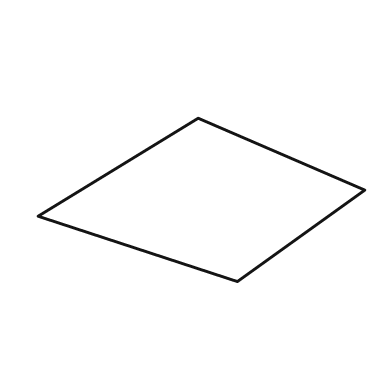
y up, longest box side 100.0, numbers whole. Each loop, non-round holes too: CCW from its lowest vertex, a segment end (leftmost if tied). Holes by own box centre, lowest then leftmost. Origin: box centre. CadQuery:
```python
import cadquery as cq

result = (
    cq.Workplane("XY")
    .moveTo(11.0, -25.0)
    .lineTo(50.0, 3.0)
    .lineTo(-1.0, 25.0)
    .lineTo(-50.0, -5.0)
    .close()
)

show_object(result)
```